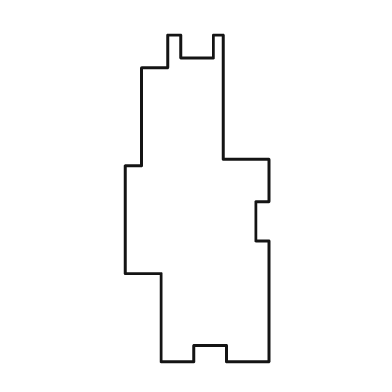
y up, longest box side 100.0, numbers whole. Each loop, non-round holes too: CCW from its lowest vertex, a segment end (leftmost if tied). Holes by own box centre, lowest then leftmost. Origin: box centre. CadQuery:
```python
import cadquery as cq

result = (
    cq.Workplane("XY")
    .moveTo(-11.0, -50.0)
    .lineTo(-1.0, -50.0)
    .lineTo(-1.0, -45.0)
    .lineTo(9.0, -45.0)
    .lineTo(9.0, -50.0)
    .lineTo(22.0, -50.0)
    .lineTo(22.0, -13.0)
    .lineTo(18.0, -13.0)
    .lineTo(18.0, -1.0)
    .lineTo(22.0, -1.0)
    .lineTo(22.0, 12.0)
    .lineTo(8.0, 12.0)
    .lineTo(8.0, 50.0)
    .lineTo(5.0, 50.0)
    .lineTo(5.0, 43.0)
    .lineTo(-5.0, 43.0)
    .lineTo(-5.0, 50.0)
    .lineTo(-9.0, 50.0)
    .lineTo(-9.0, 40.0)
    .lineTo(-17.0, 40.0)
    .lineTo(-17.0, 10.0)
    .lineTo(-22.0, 10.0)
    .lineTo(-22.0, -23.0)
    .lineTo(-11.0, -23.0)
    .close()
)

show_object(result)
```